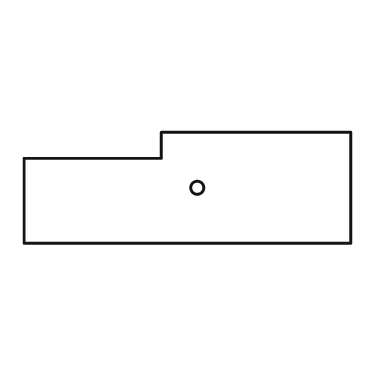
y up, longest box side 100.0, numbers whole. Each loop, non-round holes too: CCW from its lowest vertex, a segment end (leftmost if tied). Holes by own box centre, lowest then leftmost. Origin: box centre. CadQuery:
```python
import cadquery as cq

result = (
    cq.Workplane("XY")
    .moveTo(-50.0, -17.0)
    .lineTo(50.0, -17.0)
    .lineTo(50.0, 17.0)
    .lineTo(-8.0, 17.0)
    .lineTo(-8.0, 9.0)
    .lineTo(-50.0, 9.0)
    .close()
    .moveTo(3.0, 0.0)
    .circle(2.0)
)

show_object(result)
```